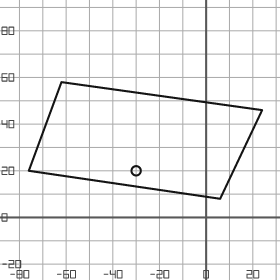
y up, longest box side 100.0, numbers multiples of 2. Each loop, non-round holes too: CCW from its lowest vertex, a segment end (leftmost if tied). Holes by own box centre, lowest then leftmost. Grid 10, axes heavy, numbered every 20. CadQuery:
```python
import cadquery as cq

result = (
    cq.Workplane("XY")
    .moveTo(6.0, 8.0)
    .lineTo(24.0, 46.0)
    .lineTo(-62.0, 58.0)
    .lineTo(-76.0, 20.0)
    .close()
    .moveTo(-30.0, 20.0)
    .circle(2.0)
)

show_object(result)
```